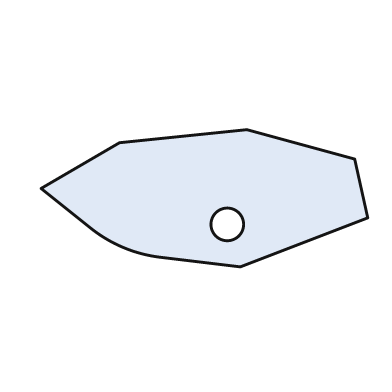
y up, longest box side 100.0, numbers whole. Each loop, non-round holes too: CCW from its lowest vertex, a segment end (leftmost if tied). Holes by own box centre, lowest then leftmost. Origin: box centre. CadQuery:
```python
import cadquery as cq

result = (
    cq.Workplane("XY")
    .moveTo(11.0, -21.0)
    .lineTo(50.0, -6.0)
    .lineTo(46.0, 12.0)
    .lineTo(13.0, 21.0)
    .lineTo(-26.0, 17.0)
    .lineTo(-50.0, 3.0)
    .lineTo(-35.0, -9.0)
    .threePointArc((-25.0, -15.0), (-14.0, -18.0))
    .close()
    .moveTo(7.0, -8.0)
    .circle(5.0)
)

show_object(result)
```